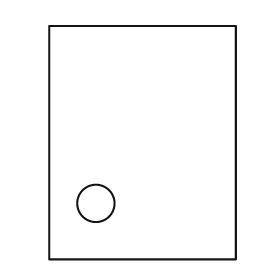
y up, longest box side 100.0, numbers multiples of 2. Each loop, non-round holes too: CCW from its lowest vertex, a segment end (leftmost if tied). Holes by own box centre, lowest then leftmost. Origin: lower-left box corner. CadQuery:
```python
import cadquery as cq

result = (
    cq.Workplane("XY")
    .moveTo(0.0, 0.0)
    .lineTo(80.0, 0.0)
    .lineTo(80.0, 100.0)
    .lineTo(0.0, 100.0)
    .close()
    .moveTo(20.0, 24.0)
    .circle(8.0)
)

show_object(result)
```